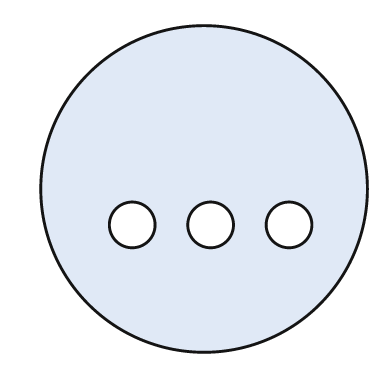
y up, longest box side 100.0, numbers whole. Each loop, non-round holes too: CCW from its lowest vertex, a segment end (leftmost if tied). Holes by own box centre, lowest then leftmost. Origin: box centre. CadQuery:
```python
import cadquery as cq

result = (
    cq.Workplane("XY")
    .moveTo(0.0, 0.0)
    .circle(50.0)
    .moveTo(-22.0, -11.0)
    .circle(7.0)
    .moveTo(2.0, -11.0)
    .circle(7.0)
    .moveTo(26.0, -11.0)
    .circle(7.0)
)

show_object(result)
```